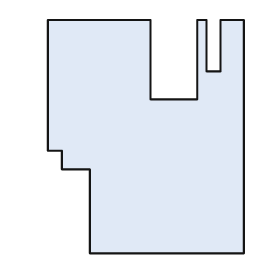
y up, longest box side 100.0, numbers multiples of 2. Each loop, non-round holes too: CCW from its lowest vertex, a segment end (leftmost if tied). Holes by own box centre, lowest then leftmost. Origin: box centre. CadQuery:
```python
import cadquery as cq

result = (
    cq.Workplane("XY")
    .moveTo(-24.0, -50.0)
    .lineTo(42.0, -50.0)
    .lineTo(42.0, 50.0)
    .lineTo(32.0, 50.0)
    .lineTo(32.0, 28.0)
    .lineTo(26.0, 28.0)
    .lineTo(26.0, 50.0)
    .lineTo(22.0, 50.0)
    .lineTo(22.0, 16.0)
    .lineTo(2.0, 16.0)
    .lineTo(2.0, 50.0)
    .lineTo(-42.0, 50.0)
    .lineTo(-42.0, -6.0)
    .lineTo(-36.0, -6.0)
    .lineTo(-36.0, -14.0)
    .lineTo(-24.0, -14.0)
    .close()
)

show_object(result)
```